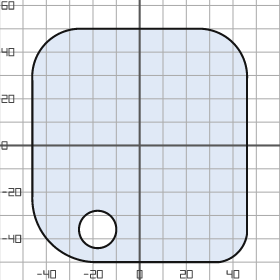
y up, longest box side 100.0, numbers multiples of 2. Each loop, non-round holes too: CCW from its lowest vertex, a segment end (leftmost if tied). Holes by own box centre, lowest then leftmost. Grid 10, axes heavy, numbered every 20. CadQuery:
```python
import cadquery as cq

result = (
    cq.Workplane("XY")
    .moveTo(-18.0, -50.0)
    .lineTo(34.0, -50.0)
    .threePointArc((42.0, -46.0), (46.0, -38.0))
    .lineTo(46.0, 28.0)
    .threePointArc((40.0, 44.0), (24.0, 50.0))
    .lineTo(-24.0, 50.0)
    .threePointArc((-40.0, 44.0), (-46.0, 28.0))
    .lineTo(-46.0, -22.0)
    .threePointArc((-38.0, -42.0), (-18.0, -50.0))
    .close()
    .moveTo(-18.0, -36.0)
    .circle(8.0)
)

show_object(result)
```